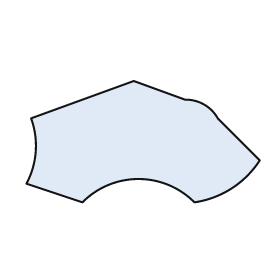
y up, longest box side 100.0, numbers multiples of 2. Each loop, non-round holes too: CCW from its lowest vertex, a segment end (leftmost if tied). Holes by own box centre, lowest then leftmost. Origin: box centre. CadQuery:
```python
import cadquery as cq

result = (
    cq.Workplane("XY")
    .moveTo(-26.0, -26.0)
    .threePointArc((-2.0, -16.0), (22.0, -26.0))
    .threePointArc((38.0, -20.0), (50.0, -8.0))
    .lineTo(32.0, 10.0)
    .threePointArc((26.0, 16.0), (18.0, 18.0))
    .lineTo(-4.0, 26.0)
    .lineTo(-48.0, 10.0)
    .threePointArc((-46.0, -4.0), (-50.0, -18.0))
    .close()
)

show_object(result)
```